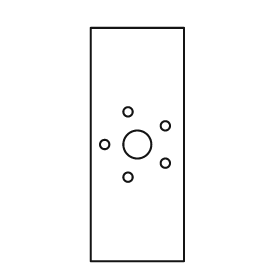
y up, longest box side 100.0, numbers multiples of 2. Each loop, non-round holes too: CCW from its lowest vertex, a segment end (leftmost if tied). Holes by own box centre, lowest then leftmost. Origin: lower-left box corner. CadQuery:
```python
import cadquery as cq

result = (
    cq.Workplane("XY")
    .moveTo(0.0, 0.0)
    .lineTo(40.0, 0.0)
    .lineTo(40.0, 100.0)
    .lineTo(0.0, 100.0)
    .close()
    .moveTo(16.0, 36.0)
    .circle(2.0)
    .moveTo(32.0, 42.0)
    .circle(2.0)
    .moveTo(6.0, 50.0)
    .circle(2.0)
    .moveTo(20.0, 50.0)
    .circle(6.0)
    .moveTo(32.0, 58.0)
    .circle(2.0)
    .moveTo(16.0, 64.0)
    .circle(2.0)
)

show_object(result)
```